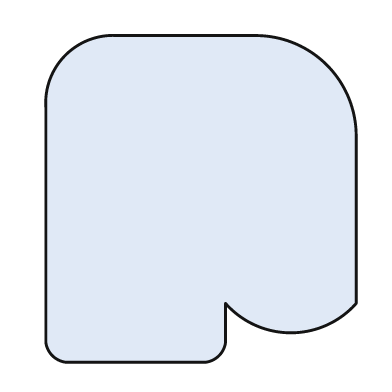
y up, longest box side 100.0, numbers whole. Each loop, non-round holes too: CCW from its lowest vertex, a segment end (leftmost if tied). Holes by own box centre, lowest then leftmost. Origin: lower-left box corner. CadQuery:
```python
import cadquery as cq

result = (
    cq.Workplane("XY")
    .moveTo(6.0, 0.0)
    .lineTo(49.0, 0.0)
    .threePointArc((53.0, 2.0), (55.0, 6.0))
    .lineTo(55.0, 18.0)
    .threePointArc((75.0, 9.0), (95.0, 18.0))
    .lineTo(95.0, 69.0)
    .threePointArc((86.0, 91.0), (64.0, 100.0))
    .lineTo(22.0, 100.0)
    .threePointArc((6.0, 94.0), (0.0, 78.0))
    .lineTo(0.0, 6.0)
    .threePointArc((2.0, 2.0), (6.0, 0.0))
    .close()
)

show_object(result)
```